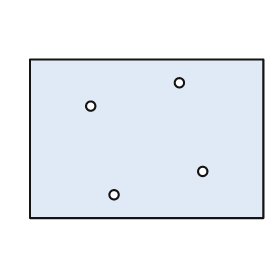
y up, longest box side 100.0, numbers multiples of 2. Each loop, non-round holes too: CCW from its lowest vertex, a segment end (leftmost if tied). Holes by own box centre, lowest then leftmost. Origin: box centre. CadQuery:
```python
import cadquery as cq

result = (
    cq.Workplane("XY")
    .moveTo(-50.0, -34.0)
    .lineTo(50.0, -34.0)
    .lineTo(50.0, 34.0)
    .lineTo(-50.0, 34.0)
    .close()
    .moveTo(-14.0, -24.0)
    .circle(2.0)
    .moveTo(24.0, -14.0)
    .circle(2.0)
    .moveTo(-24.0, 14.0)
    .circle(2.0)
    .moveTo(14.0, 24.0)
    .circle(2.0)
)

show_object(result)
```